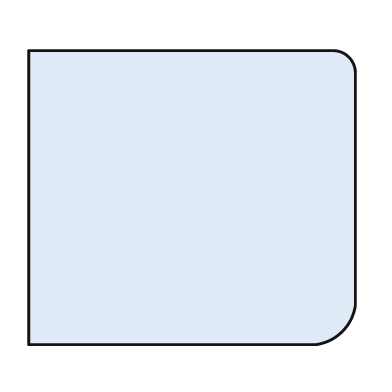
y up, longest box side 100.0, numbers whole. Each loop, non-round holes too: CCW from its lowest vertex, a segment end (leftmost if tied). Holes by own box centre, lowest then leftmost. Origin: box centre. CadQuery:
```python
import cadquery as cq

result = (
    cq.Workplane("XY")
    .moveTo(-50.0, -45.0)
    .lineTo(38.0, -45.0)
    .threePointArc((46.0, -41.0), (50.0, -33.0))
    .lineTo(50.0, 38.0)
    .threePointArc((48.0, 43.0), (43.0, 45.0))
    .lineTo(-50.0, 45.0)
    .close()
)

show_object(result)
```